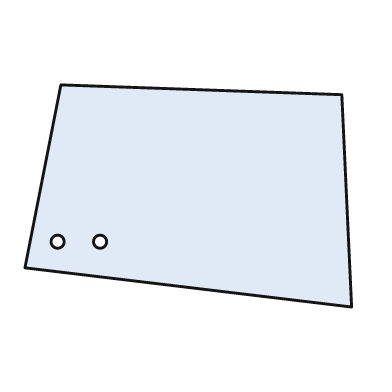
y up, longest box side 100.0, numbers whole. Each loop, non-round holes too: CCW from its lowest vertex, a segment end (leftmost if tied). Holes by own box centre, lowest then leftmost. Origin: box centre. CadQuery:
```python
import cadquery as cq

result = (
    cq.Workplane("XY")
    .moveTo(50.0, -34.0)
    .lineTo(47.0, 31.0)
    .lineTo(-39.0, 34.0)
    .lineTo(-50.0, -22.0)
    .close()
    .moveTo(-40.0, -14.0)
    .circle(2.0)
    .moveTo(-27.0, -14.0)
    .circle(2.0)
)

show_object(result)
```